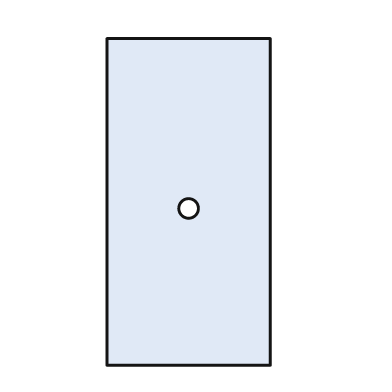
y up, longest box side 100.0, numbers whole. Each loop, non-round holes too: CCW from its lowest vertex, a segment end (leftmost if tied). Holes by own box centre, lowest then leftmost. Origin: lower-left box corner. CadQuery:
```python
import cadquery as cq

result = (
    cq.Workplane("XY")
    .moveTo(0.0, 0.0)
    .lineTo(50.0, 0.0)
    .lineTo(50.0, 100.0)
    .lineTo(0.0, 100.0)
    .close()
    .moveTo(25.0, 48.0)
    .circle(3.0)
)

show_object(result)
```